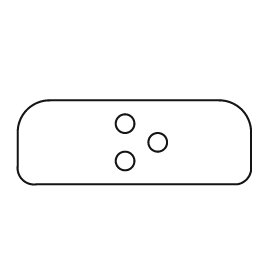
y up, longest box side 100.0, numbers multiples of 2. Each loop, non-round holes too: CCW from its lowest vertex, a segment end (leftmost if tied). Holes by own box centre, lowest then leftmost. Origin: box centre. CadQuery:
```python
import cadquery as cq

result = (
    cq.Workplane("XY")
    .moveTo(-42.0, -18.0)
    .lineTo(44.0, -18.0)
    .threePointArc((48.0, -16.0), (50.0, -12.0))
    .lineTo(50.0, 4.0)
    .threePointArc((46.0, 14.0), (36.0, 18.0))
    .lineTo(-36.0, 18.0)
    .threePointArc((-46.0, 14.0), (-50.0, 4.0))
    .lineTo(-50.0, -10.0)
    .threePointArc((-48.0, -16.0), (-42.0, -18.0))
    .close()
    .moveTo(-4.0, -8.0)
    .circle(4.0)
    .moveTo(10.0, 0.0)
    .circle(4.0)
    .moveTo(-4.0, 8.0)
    .circle(4.0)
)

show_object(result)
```